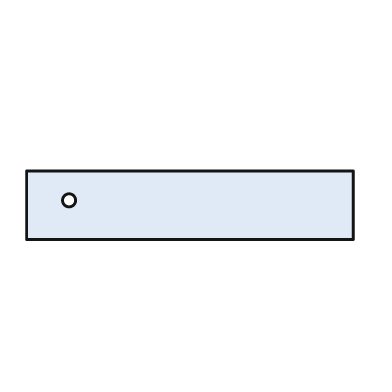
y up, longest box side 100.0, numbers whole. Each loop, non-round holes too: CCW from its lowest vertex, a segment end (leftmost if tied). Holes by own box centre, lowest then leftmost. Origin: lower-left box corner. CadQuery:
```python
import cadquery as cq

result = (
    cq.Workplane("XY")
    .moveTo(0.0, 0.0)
    .lineTo(100.0, 0.0)
    .lineTo(100.0, 21.0)
    .lineTo(0.0, 21.0)
    .close()
    .moveTo(13.0, 12.0)
    .circle(2.0)
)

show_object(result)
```